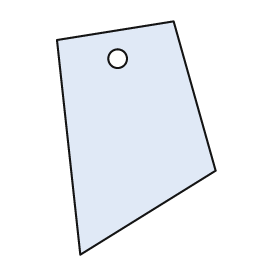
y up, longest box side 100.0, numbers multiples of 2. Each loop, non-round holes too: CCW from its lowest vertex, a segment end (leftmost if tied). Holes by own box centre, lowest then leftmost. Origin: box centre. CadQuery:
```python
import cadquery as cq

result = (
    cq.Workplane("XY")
    .moveTo(-24.0, -50.0)
    .lineTo(34.0, -14.0)
    .lineTo(16.0, 50.0)
    .lineTo(-34.0, 42.0)
    .close()
    .moveTo(-8.0, 34.0)
    .circle(4.0)
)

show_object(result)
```